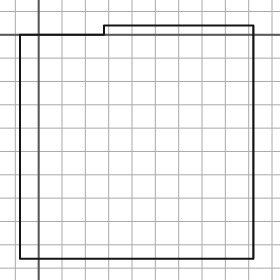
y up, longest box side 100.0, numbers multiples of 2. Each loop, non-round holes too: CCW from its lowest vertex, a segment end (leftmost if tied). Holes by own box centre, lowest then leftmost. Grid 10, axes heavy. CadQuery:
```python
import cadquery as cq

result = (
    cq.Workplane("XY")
    .moveTo(-8.0, -96.0)
    .lineTo(92.0, -96.0)
    .lineTo(92.0, 4.0)
    .lineTo(28.0, 4.0)
    .lineTo(28.0, 0.0)
    .lineTo(-8.0, 0.0)
    .close()
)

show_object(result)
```